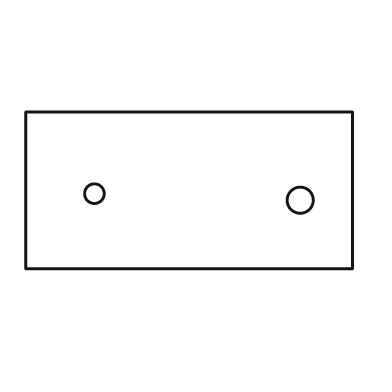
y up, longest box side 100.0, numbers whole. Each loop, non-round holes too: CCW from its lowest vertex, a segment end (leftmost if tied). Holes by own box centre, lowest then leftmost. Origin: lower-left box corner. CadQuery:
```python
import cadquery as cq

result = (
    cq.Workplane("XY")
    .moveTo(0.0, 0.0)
    .lineTo(100.0, 0.0)
    .lineTo(100.0, 48.0)
    .lineTo(0.0, 48.0)
    .close()
    .moveTo(84.0, 21.0)
    .circle(4.0)
    .moveTo(21.0, 23.0)
    .circle(3.0)
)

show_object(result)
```